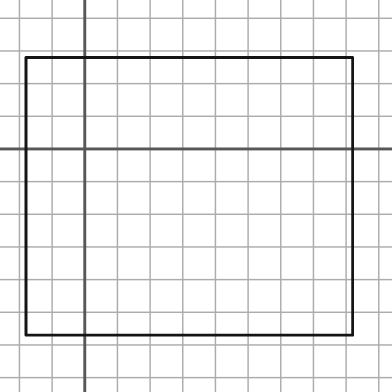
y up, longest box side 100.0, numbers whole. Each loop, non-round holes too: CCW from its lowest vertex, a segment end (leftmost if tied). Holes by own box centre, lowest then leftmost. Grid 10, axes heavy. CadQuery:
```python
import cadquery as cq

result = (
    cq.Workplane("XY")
    .moveTo(-18.0, -57.0)
    .lineTo(82.0, -57.0)
    .lineTo(82.0, 28.0)
    .lineTo(-18.0, 28.0)
    .close()
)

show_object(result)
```